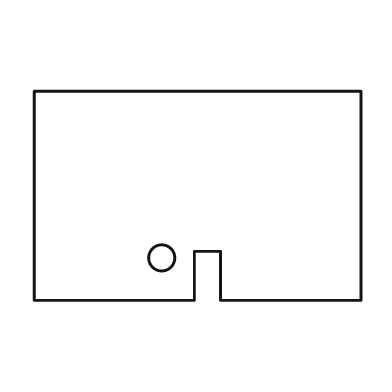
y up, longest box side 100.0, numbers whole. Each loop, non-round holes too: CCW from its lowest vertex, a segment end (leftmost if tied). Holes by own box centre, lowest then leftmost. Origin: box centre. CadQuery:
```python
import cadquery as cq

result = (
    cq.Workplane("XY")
    .moveTo(-50.0, -32.0)
    .lineTo(-1.0, -32.0)
    .lineTo(-1.0, -17.0)
    .lineTo(7.0, -17.0)
    .lineTo(7.0, -32.0)
    .lineTo(50.0, -32.0)
    .lineTo(50.0, 32.0)
    .lineTo(-50.0, 32.0)
    .close()
    .moveTo(-11.0, -19.0)
    .circle(4.0)
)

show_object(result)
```